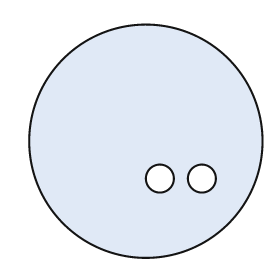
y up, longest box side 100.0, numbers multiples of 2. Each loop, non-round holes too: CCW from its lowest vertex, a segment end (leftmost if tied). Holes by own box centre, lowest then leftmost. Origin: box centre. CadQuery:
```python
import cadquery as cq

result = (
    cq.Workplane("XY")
    .moveTo(0.0, 0.0)
    .circle(50.0)
    .moveTo(6.0, -16.0)
    .circle(6.0)
    .moveTo(24.0, -16.0)
    .circle(6.0)
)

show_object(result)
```